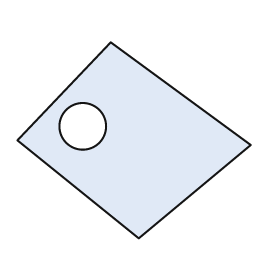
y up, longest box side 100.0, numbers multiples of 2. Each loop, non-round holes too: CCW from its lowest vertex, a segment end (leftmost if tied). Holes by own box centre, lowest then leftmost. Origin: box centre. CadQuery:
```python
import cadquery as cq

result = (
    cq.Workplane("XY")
    .moveTo(2.0, -42.0)
    .lineTo(50.0, -2.0)
    .lineTo(-10.0, 42.0)
    .lineTo(-50.0, 0.0)
    .close()
    .moveTo(-22.0, 6.0)
    .circle(10.0)
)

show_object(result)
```